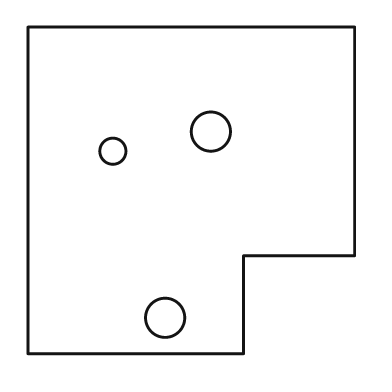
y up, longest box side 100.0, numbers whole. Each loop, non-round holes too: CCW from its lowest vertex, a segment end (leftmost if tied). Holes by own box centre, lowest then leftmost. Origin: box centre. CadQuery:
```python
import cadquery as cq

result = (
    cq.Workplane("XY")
    .moveTo(-50.0, -50.0)
    .lineTo(16.0, -50.0)
    .lineTo(16.0, -20.0)
    .lineTo(50.0, -20.0)
    .lineTo(50.0, 50.0)
    .lineTo(-50.0, 50.0)
    .close()
    .moveTo(-8.0, -39.0)
    .circle(6.0)
    .moveTo(-24.0, 12.0)
    .circle(4.0)
    .moveTo(6.0, 18.0)
    .circle(6.0)
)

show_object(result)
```